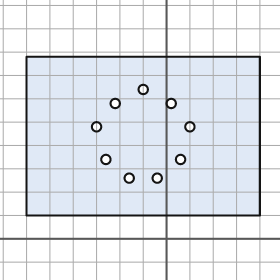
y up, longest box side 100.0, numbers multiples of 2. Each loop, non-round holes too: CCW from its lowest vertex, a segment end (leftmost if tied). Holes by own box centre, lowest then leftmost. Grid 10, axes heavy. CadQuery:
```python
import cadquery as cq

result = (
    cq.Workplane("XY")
    .moveTo(-60.0, 10.0)
    .lineTo(40.0, 10.0)
    .lineTo(40.0, 78.0)
    .lineTo(-60.0, 78.0)
    .close()
    .moveTo(-16.0, 26.0)
    .circle(2.0)
    .moveTo(-4.0, 26.0)
    .circle(2.0)
    .moveTo(-26.0, 34.0)
    .circle(2.0)
    .moveTo(6.0, 34.0)
    .circle(2.0)
    .moveTo(-30.0, 48.0)
    .circle(2.0)
    .moveTo(10.0, 48.0)
    .circle(2.0)
    .moveTo(-22.0, 58.0)
    .circle(2.0)
    .moveTo(2.0, 58.0)
    .circle(2.0)
    .moveTo(-10.0, 64.0)
    .circle(2.0)
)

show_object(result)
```